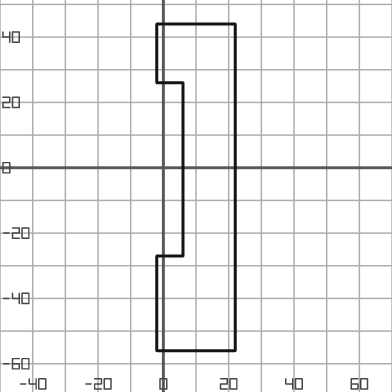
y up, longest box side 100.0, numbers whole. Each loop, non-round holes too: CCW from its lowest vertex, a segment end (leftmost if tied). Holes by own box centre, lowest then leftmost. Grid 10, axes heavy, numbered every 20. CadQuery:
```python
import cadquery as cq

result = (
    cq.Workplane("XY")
    .moveTo(-2.0, -56.0)
    .lineTo(22.0, -56.0)
    .lineTo(22.0, 44.0)
    .lineTo(-2.0, 44.0)
    .lineTo(-2.0, 26.0)
    .lineTo(6.0, 26.0)
    .lineTo(6.0, -27.0)
    .lineTo(-2.0, -27.0)
    .close()
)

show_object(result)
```